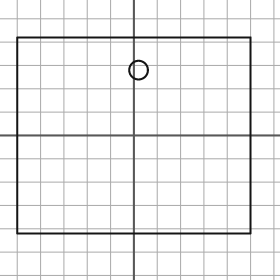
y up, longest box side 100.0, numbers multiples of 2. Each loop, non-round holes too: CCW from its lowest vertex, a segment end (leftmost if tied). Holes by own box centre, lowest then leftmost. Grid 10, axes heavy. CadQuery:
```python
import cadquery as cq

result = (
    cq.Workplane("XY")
    .moveTo(-50.0, -42.0)
    .lineTo(50.0, -42.0)
    .lineTo(50.0, 42.0)
    .lineTo(-50.0, 42.0)
    .close()
    .moveTo(2.0, 28.0)
    .circle(4.0)
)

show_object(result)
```